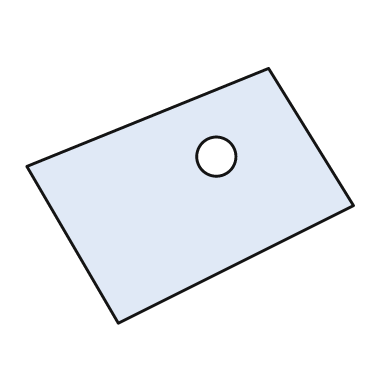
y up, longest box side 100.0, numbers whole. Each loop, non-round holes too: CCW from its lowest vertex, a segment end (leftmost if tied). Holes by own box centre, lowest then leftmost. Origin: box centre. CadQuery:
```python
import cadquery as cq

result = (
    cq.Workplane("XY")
    .moveTo(-22.0, -39.0)
    .lineTo(50.0, -3.0)
    .lineTo(24.0, 39.0)
    .lineTo(-50.0, 9.0)
    .close()
    .moveTo(8.0, 12.0)
    .circle(6.0)
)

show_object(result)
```